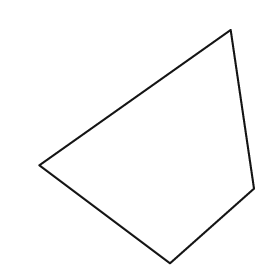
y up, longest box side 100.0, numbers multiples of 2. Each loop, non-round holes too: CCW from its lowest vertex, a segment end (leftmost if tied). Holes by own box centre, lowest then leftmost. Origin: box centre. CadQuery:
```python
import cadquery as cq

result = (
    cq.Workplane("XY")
    .moveTo(10.0, -50.0)
    .lineTo(46.0, -18.0)
    .lineTo(36.0, 50.0)
    .lineTo(-46.0, -8.0)
    .close()
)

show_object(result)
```